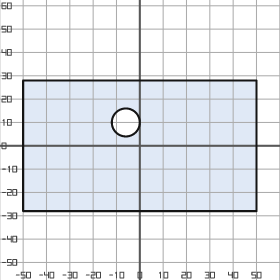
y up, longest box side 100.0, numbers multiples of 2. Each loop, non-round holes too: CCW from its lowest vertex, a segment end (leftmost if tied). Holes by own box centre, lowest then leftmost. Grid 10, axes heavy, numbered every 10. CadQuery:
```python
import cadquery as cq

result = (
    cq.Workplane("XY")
    .moveTo(-50.0, -28.0)
    .lineTo(50.0, -28.0)
    .lineTo(50.0, 28.0)
    .lineTo(-50.0, 28.0)
    .close()
    .moveTo(-6.0, 10.0)
    .circle(6.0)
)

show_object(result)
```